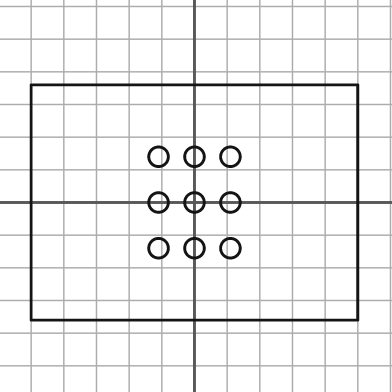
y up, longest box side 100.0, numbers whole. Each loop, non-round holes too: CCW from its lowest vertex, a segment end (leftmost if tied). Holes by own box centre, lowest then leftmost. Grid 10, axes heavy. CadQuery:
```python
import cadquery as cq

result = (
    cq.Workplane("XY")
    .moveTo(-50.0, -36.0)
    .lineTo(50.0, -36.0)
    .lineTo(50.0, 36.0)
    .lineTo(-50.0, 36.0)
    .close()
    .moveTo(-11.0, -14.0)
    .circle(3.0)
    .moveTo(0.0, -14.0)
    .circle(3.0)
    .moveTo(11.0, -14.0)
    .circle(3.0)
    .moveTo(-11.0, 0.0)
    .circle(3.0)
    .moveTo(0.0, 0.0)
    .circle(3.0)
    .moveTo(11.0, 0.0)
    .circle(3.0)
    .moveTo(-11.0, 14.0)
    .circle(3.0)
    .moveTo(0.0, 14.0)
    .circle(3.0)
    .moveTo(11.0, 14.0)
    .circle(3.0)
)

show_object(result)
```